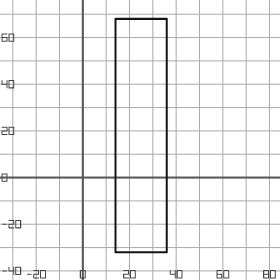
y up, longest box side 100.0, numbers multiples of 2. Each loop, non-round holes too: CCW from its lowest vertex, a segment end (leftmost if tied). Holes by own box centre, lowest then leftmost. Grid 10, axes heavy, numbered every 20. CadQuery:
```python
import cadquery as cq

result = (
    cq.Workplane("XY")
    .moveTo(14.0, -32.0)
    .lineTo(36.0, -32.0)
    .lineTo(36.0, 68.0)
    .lineTo(14.0, 68.0)
    .close()
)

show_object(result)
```